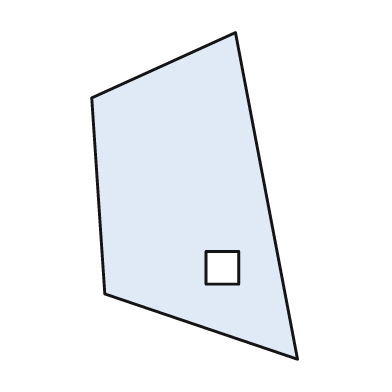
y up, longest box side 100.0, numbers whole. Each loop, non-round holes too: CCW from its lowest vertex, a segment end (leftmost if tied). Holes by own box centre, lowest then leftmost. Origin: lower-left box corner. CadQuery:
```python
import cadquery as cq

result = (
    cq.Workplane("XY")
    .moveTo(63.0, 0.0)
    .lineTo(44.0, 100.0)
    .lineTo(0.0, 80.0)
    .lineTo(4.0, 20.0)
    .close()
    .moveTo(35.0, 23.0)
    .lineTo(45.0, 23.0)
    .lineTo(45.0, 33.0)
    .lineTo(35.0, 33.0)
    .close()
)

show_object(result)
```